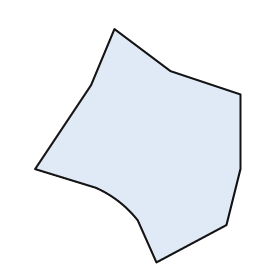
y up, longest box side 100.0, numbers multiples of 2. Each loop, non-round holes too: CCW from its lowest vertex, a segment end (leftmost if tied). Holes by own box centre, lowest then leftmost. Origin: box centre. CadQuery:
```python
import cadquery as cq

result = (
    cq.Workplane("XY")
    .moveTo(8.0, -50.0)
    .lineTo(38.0, -34.0)
    .lineTo(44.0, -10.0)
    .lineTo(44.0, 22.0)
    .lineTo(14.0, 32.0)
    .lineTo(-10.0, 50.0)
    .lineTo(-20.0, 26.0)
    .lineTo(-44.0, -10.0)
    .lineTo(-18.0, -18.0)
    .threePointArc((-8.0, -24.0), (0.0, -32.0))
    .close()
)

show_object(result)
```